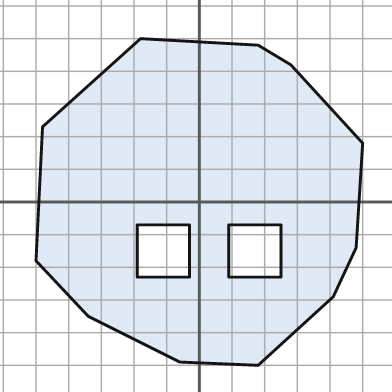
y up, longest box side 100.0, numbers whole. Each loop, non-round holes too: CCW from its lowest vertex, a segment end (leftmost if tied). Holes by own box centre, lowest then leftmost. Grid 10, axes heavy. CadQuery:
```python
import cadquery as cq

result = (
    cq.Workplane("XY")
    .moveTo(18.0, -50.0)
    .lineTo(41.0, -29.0)
    .lineTo(48.0, -14.0)
    .lineTo(50.0, 18.0)
    .lineTo(28.0, 42.0)
    .lineTo(18.0, 48.0)
    .lineTo(-18.0, 50.0)
    .lineTo(-48.0, 23.0)
    .lineTo(-50.0, -18.0)
    .lineTo(-34.0, -35.0)
    .lineTo(-6.0, -49.0)
    .close()
    .moveTo(-19.0, -23.0)
    .lineTo(-3.0, -23.0)
    .lineTo(-3.0, -7.0)
    .lineTo(-19.0, -7.0)
    .close()
    .moveTo(9.0, -23.0)
    .lineTo(25.0, -23.0)
    .lineTo(25.0, -7.0)
    .lineTo(9.0, -7.0)
    .close()
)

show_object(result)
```